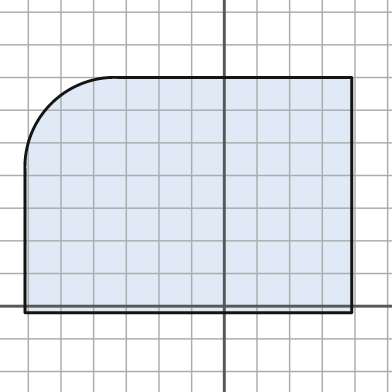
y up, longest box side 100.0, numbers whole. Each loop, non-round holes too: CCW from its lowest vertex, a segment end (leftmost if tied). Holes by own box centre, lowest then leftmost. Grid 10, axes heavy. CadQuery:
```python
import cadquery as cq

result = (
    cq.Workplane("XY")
    .moveTo(-61.0, -2.0)
    .lineTo(39.0, -2.0)
    .lineTo(39.0, 70.0)
    .lineTo(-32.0, 70.0)
    .threePointArc((-53.0, 62.0), (-61.0, 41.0))
    .close()
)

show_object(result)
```